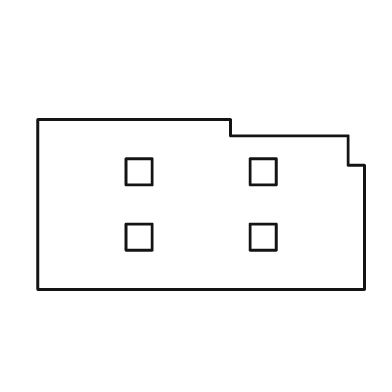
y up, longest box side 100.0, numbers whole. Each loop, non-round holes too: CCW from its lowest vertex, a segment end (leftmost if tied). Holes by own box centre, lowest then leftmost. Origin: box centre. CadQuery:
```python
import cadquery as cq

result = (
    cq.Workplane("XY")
    .moveTo(-50.0, -26.0)
    .lineTo(50.0, -26.0)
    .lineTo(50.0, 12.0)
    .lineTo(45.0, 12.0)
    .lineTo(45.0, 21.0)
    .lineTo(9.0, 21.0)
    .lineTo(9.0, 26.0)
    .lineTo(-50.0, 26.0)
    .close()
    .moveTo(-23.0, -14.0)
    .lineTo(-15.0, -14.0)
    .lineTo(-15.0, -6.0)
    .lineTo(-23.0, -6.0)
    .close()
    .moveTo(15.0, -14.0)
    .lineTo(23.0, -14.0)
    .lineTo(23.0, -6.0)
    .lineTo(15.0, -6.0)
    .close()
    .moveTo(-23.0, 6.0)
    .lineTo(-15.0, 6.0)
    .lineTo(-15.0, 14.0)
    .lineTo(-23.0, 14.0)
    .close()
    .moveTo(15.0, 6.0)
    .lineTo(23.0, 6.0)
    .lineTo(23.0, 14.0)
    .lineTo(15.0, 14.0)
    .close()
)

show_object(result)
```